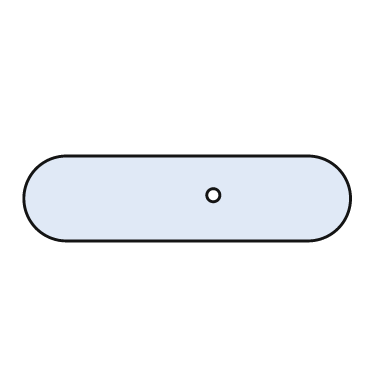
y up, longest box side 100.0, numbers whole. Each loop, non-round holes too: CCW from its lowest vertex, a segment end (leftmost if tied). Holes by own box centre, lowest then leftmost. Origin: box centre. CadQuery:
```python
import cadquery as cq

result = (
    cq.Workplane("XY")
    .moveTo(-37.0, -13.0)
    .lineTo(37.0, -13.0)
    .threePointArc((50.0, 0.0), (37.0, 13.0))
    .lineTo(-37.0, 13.0)
    .threePointArc((-50.0, 0.0), (-37.0, -13.0))
    .close()
    .moveTo(8.0, 1.0)
    .circle(2.0)
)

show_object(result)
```